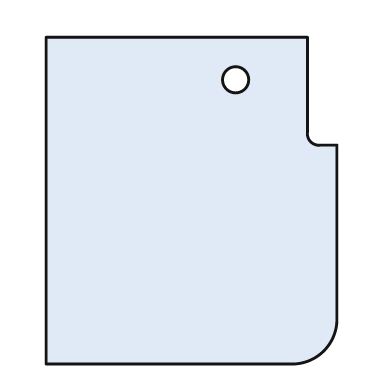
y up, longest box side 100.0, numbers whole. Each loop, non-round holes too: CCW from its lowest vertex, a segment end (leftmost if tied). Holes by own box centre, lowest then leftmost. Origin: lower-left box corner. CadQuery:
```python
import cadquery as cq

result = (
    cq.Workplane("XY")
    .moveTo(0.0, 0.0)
    .lineTo(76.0, 0.0)
    .threePointArc((85.0, 4.0), (89.0, 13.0))
    .lineTo(89.0, 67.0)
    .lineTo(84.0, 67.0)
    .threePointArc((81.0, 68.0), (80.0, 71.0))
    .lineTo(80.0, 100.0)
    .lineTo(0.0, 100.0)
    .close()
    .moveTo(58.0, 87.0)
    .circle(4.0)
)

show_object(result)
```